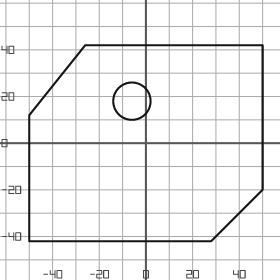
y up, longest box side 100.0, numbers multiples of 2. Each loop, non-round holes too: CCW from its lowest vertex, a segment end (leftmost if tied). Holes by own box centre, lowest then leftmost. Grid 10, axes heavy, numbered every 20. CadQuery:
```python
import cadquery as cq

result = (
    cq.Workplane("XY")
    .moveTo(-50.0, -42.0)
    .lineTo(28.0, -42.0)
    .lineTo(50.0, -20.0)
    .lineTo(50.0, 42.0)
    .lineTo(-26.0, 42.0)
    .lineTo(-50.0, 12.0)
    .close()
    .moveTo(-6.0, 18.0)
    .circle(8.0)
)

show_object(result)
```